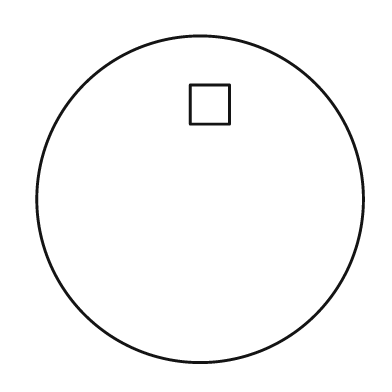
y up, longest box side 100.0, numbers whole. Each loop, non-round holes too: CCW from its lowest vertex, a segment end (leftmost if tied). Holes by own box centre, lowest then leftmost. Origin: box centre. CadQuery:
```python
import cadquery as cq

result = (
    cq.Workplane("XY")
    .moveTo(0.0, 0.0)
    .circle(50.0)
    .moveTo(-3.0, 23.0)
    .lineTo(9.0, 23.0)
    .lineTo(9.0, 35.0)
    .lineTo(-3.0, 35.0)
    .close()
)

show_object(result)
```